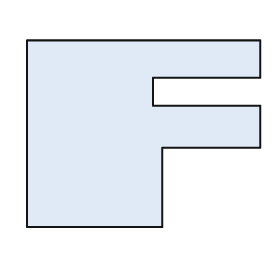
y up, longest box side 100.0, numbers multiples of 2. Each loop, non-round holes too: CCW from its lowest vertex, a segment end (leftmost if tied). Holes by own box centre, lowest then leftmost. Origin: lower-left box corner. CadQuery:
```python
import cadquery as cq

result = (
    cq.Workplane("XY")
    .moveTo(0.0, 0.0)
    .lineTo(58.0, 0.0)
    .lineTo(58.0, 34.0)
    .lineTo(100.0, 34.0)
    .lineTo(100.0, 52.0)
    .lineTo(54.0, 52.0)
    .lineTo(54.0, 64.0)
    .lineTo(100.0, 64.0)
    .lineTo(100.0, 80.0)
    .lineTo(0.0, 80.0)
    .close()
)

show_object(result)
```